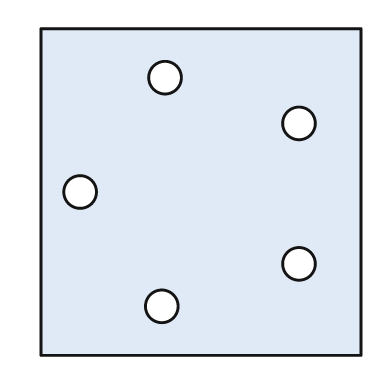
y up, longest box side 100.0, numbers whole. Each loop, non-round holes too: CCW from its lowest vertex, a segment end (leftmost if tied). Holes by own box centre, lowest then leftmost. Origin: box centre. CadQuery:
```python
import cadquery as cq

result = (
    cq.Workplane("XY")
    .moveTo(-49.0, -50.0)
    .lineTo(49.0, -50.0)
    .lineTo(49.0, 50.0)
    .lineTo(-49.0, 50.0)
    .close()
    .moveTo(-12.0, -35.0)
    .circle(5.0)
    .moveTo(30.0, -22.0)
    .circle(5.0)
    .moveTo(-37.0, 0.0)
    .circle(5.0)
    .moveTo(30.0, 21.0)
    .circle(5.0)
    .moveTo(-11.0, 35.0)
    .circle(5.0)
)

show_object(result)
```